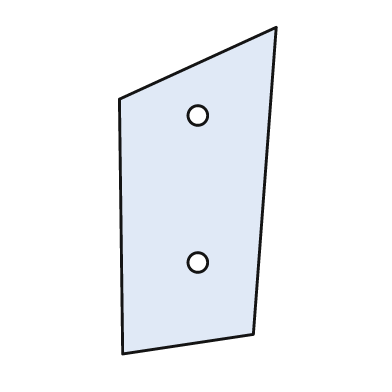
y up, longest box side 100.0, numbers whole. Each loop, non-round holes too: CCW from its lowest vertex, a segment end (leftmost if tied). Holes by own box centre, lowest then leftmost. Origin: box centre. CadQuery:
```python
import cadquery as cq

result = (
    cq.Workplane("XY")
    .moveTo(-23.0, -50.0)
    .lineTo(17.0, -44.0)
    .lineTo(24.0, 50.0)
    .lineTo(-24.0, 28.0)
    .close()
    .moveTo(0.0, -22.0)
    .circle(3.0)
    .moveTo(0.0, 23.0)
    .circle(3.0)
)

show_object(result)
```